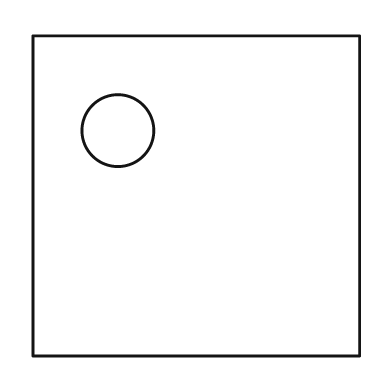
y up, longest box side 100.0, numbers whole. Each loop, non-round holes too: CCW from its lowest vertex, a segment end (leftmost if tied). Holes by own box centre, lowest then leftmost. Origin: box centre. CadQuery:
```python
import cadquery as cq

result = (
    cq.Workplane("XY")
    .moveTo(-50.0, -49.0)
    .lineTo(50.0, -49.0)
    .lineTo(50.0, 49.0)
    .lineTo(-50.0, 49.0)
    .close()
    .moveTo(-24.0, 20.0)
    .circle(11.0)
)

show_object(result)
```